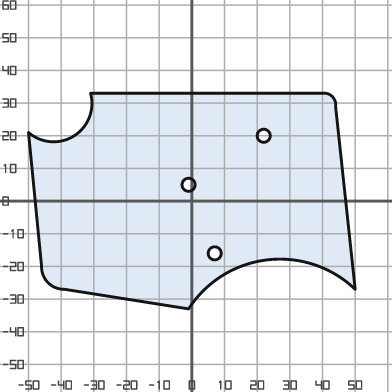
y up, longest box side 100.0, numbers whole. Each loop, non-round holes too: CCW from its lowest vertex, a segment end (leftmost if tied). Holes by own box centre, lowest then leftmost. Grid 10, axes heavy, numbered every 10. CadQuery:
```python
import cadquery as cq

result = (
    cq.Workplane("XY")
    .moveTo(-1.0, -33.0)
    .threePointArc((23.0, -18.0), (50.0, -27.0))
    .lineTo(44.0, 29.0)
    .threePointArc((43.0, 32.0), (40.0, 33.0))
    .lineTo(-31.0, 33.0)
    .threePointArc((-36.0, 20.0), (-50.0, 21.0))
    .lineTo(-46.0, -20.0)
    .threePointArc((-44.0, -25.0), (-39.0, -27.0))
    .close()
    .moveTo(7.0, -16.0)
    .circle(2.0)
    .moveTo(-1.0, 5.0)
    .circle(2.0)
    .moveTo(22.0, 20.0)
    .circle(2.0)
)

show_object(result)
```